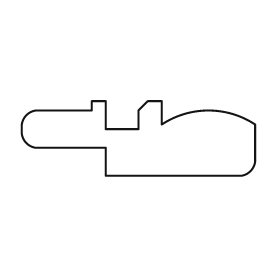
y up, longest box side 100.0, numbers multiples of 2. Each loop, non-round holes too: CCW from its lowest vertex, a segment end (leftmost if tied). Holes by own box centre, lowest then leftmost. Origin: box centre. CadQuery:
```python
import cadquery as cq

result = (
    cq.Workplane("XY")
    .moveTo(-14.0, -16.0)
    .lineTo(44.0, -16.0)
    .threePointArc((48.0, -14.0), (50.0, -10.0))
    .lineTo(50.0, 6.0)
    .threePointArc((30.0, 12.0), (10.0, 6.0))
    .lineTo(10.0, 16.0)
    .lineTo(4.0, 16.0)
    .lineTo(0.0, 12.0)
    .lineTo(0.0, 4.0)
    .lineTo(-14.0, 4.0)
    .lineTo(-14.0, 16.0)
    .lineTo(-20.0, 16.0)
    .lineTo(-20.0, 12.0)
    .lineTo(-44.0, 12.0)
    .threePointArc((-48.0, 10.0), (-50.0, 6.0))
    .lineTo(-50.0, 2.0)
    .threePointArc((-48.0, -2.0), (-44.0, -4.0))
    .lineTo(-14.0, -4.0)
    .close()
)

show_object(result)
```